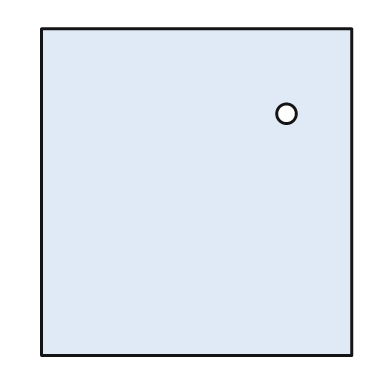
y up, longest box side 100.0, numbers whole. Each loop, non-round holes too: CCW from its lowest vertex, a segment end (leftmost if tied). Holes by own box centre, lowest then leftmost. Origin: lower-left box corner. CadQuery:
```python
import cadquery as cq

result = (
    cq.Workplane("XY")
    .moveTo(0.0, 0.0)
    .lineTo(95.0, 0.0)
    .lineTo(95.0, 100.0)
    .lineTo(0.0, 100.0)
    .close()
    .moveTo(75.0, 74.0)
    .circle(3.0)
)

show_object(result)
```